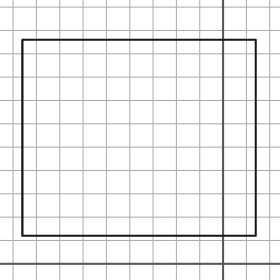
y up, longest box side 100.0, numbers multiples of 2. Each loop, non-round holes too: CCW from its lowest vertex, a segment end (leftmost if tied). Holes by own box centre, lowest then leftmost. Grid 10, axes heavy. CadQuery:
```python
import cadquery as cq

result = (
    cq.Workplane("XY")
    .moveTo(-86.0, 12.0)
    .lineTo(14.0, 12.0)
    .lineTo(14.0, 96.0)
    .lineTo(-86.0, 96.0)
    .close()
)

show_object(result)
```